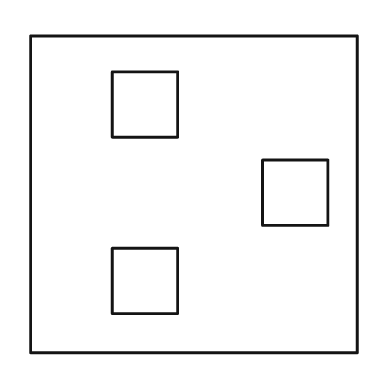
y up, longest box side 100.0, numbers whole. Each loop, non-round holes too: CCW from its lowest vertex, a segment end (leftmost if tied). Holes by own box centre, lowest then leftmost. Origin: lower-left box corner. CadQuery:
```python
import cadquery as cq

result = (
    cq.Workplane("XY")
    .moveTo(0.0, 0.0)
    .lineTo(100.0, 0.0)
    .lineTo(100.0, 97.0)
    .lineTo(0.0, 97.0)
    .close()
    .moveTo(25.0, 12.0)
    .lineTo(45.0, 12.0)
    .lineTo(45.0, 32.0)
    .lineTo(25.0, 32.0)
    .close()
    .moveTo(71.0, 39.0)
    .lineTo(91.0, 39.0)
    .lineTo(91.0, 59.0)
    .lineTo(71.0, 59.0)
    .close()
    .moveTo(25.0, 66.0)
    .lineTo(45.0, 66.0)
    .lineTo(45.0, 86.0)
    .lineTo(25.0, 86.0)
    .close()
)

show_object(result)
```